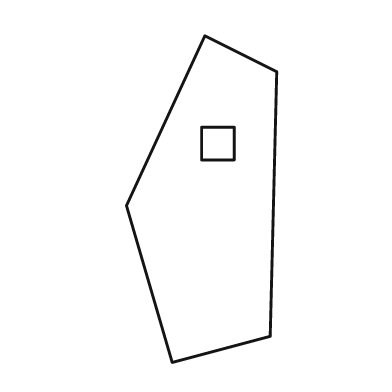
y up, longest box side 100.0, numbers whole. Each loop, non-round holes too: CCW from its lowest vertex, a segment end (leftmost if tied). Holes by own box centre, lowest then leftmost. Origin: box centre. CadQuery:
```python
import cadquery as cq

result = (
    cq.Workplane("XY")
    .moveTo(-9.0, -50.0)
    .lineTo(21.0, -42.0)
    .lineTo(23.0, 39.0)
    .lineTo(1.0, 50.0)
    .lineTo(-23.0, -2.0)
    .close()
    .moveTo(0.0, 12.0)
    .lineTo(10.0, 12.0)
    .lineTo(10.0, 22.0)
    .lineTo(0.0, 22.0)
    .close()
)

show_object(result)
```